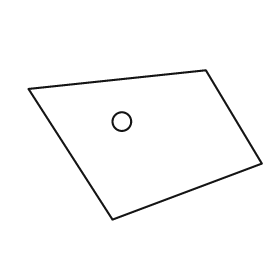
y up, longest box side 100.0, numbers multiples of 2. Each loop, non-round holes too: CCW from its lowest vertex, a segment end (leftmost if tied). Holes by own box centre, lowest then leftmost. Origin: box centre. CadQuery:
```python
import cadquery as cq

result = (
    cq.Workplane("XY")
    .moveTo(-14.0, -32.0)
    .lineTo(50.0, -8.0)
    .lineTo(26.0, 32.0)
    .lineTo(-50.0, 24.0)
    .close()
    .moveTo(-10.0, 10.0)
    .circle(4.0)
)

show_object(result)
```